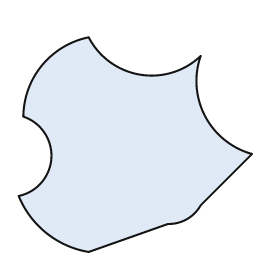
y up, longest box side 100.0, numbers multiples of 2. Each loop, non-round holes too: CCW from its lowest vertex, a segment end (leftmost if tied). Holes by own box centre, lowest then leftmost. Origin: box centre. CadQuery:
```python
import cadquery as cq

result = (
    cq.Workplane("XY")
    .moveTo(-20.0, -46.0)
    .lineTo(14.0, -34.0)
    .threePointArc((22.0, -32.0), (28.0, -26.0))
    .lineTo(50.0, -4.0)
    .threePointArc((30.0, 12.0), (28.0, 38.0))
    .threePointArc((2.0, 30.0), (-20.0, 46.0))
    .threePointArc((-40.0, 34.0), (-48.0, 12.0))
    .threePointArc((-36.0, -6.0), (-50.0, -22.0))
    .threePointArc((-38.0, -38.0), (-20.0, -46.0))
    .close()
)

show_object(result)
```